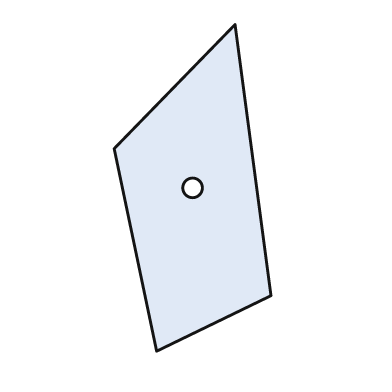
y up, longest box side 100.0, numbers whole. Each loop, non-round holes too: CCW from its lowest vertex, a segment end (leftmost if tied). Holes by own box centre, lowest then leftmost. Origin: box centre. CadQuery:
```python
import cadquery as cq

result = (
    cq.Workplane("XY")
    .moveTo(-11.0, -50.0)
    .lineTo(24.0, -33.0)
    .lineTo(13.0, 50.0)
    .lineTo(-24.0, 12.0)
    .close()
    .moveTo(0.0, 0.0)
    .circle(3.0)
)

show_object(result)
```